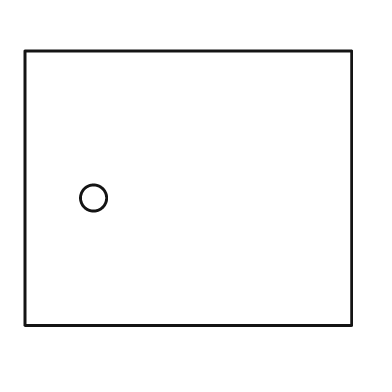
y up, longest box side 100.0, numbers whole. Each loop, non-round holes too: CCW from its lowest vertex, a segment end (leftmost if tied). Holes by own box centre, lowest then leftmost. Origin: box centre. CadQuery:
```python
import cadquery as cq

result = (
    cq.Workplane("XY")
    .moveTo(-50.0, -42.0)
    .lineTo(50.0, -42.0)
    .lineTo(50.0, 42.0)
    .lineTo(-50.0, 42.0)
    .close()
    .moveTo(-29.0, -3.0)
    .circle(4.0)
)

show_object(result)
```